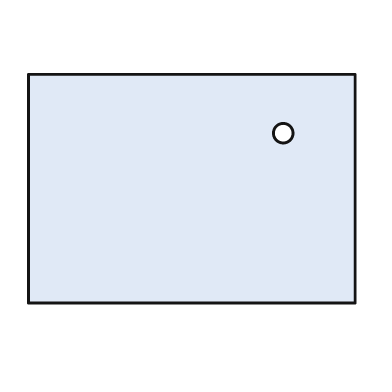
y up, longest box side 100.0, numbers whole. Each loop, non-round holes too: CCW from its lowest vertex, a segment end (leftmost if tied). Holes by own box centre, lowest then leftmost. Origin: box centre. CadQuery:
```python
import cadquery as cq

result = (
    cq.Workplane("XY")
    .moveTo(-50.0, -35.0)
    .lineTo(50.0, -35.0)
    .lineTo(50.0, 35.0)
    .lineTo(-50.0, 35.0)
    .close()
    .moveTo(28.0, 17.0)
    .circle(3.0)
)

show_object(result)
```